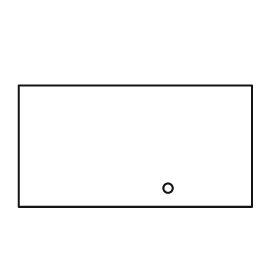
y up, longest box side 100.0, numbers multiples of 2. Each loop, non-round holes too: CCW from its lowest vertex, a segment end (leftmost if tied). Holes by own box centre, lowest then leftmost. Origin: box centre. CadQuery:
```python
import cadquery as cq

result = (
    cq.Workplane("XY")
    .moveTo(-50.0, -26.0)
    .lineTo(50.0, -26.0)
    .lineTo(50.0, 26.0)
    .lineTo(-50.0, 26.0)
    .close()
    .moveTo(14.0, -18.0)
    .circle(2.0)
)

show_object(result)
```